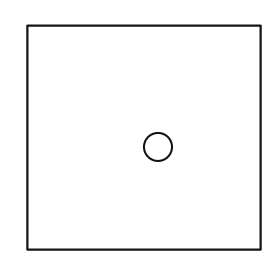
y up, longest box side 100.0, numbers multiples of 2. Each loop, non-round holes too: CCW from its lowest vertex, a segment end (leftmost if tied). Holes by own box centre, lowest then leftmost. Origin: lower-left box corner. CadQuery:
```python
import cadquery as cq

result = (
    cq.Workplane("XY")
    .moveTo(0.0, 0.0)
    .lineTo(100.0, 0.0)
    .lineTo(100.0, 96.0)
    .lineTo(0.0, 96.0)
    .close()
    .moveTo(56.0, 44.0)
    .circle(6.0)
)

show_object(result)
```